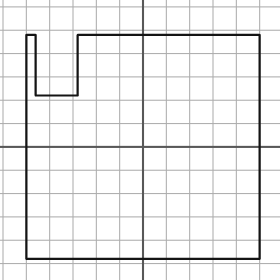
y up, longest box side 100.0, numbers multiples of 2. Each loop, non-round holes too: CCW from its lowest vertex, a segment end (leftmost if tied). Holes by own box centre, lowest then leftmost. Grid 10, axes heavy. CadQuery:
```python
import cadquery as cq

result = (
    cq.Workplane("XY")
    .moveTo(-50.0, -48.0)
    .lineTo(50.0, -48.0)
    .lineTo(50.0, 48.0)
    .lineTo(-28.0, 48.0)
    .lineTo(-28.0, 22.0)
    .lineTo(-46.0, 22.0)
    .lineTo(-46.0, 48.0)
    .lineTo(-50.0, 48.0)
    .close()
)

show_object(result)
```